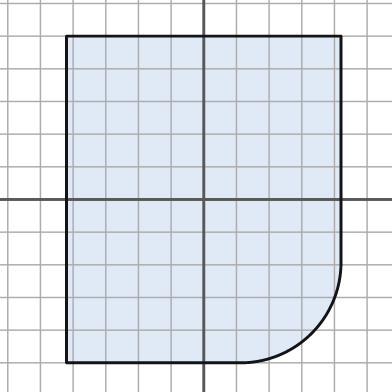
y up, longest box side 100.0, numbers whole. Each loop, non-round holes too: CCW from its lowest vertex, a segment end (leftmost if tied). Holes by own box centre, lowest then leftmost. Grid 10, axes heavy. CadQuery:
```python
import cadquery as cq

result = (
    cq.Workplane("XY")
    .moveTo(-42.0, -50.0)
    .lineTo(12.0, -50.0)
    .threePointArc((33.0, -41.0), (42.0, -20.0))
    .lineTo(42.0, 50.0)
    .lineTo(-42.0, 50.0)
    .close()
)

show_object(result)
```